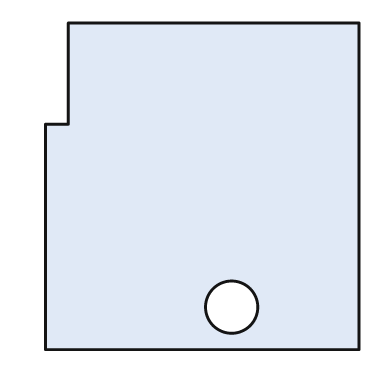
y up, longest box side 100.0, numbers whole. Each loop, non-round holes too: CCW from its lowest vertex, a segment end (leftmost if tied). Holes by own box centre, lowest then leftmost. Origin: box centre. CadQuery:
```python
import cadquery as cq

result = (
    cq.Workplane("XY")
    .moveTo(-48.0, -50.0)
    .lineTo(48.0, -50.0)
    .lineTo(48.0, 50.0)
    .lineTo(-41.0, 50.0)
    .lineTo(-41.0, 19.0)
    .lineTo(-48.0, 19.0)
    .close()
    .moveTo(9.0, -37.0)
    .circle(8.0)
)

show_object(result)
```